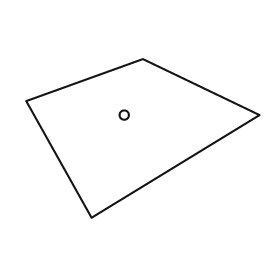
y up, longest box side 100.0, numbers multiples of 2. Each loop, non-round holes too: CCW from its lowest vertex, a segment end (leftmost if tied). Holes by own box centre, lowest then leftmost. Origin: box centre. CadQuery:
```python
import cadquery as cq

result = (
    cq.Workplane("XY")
    .moveTo(-22.0, -34.0)
    .lineTo(50.0, 10.0)
    .lineTo(0.0, 34.0)
    .lineTo(-50.0, 16.0)
    .close()
    .moveTo(-8.0, 10.0)
    .circle(2.0)
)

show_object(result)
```